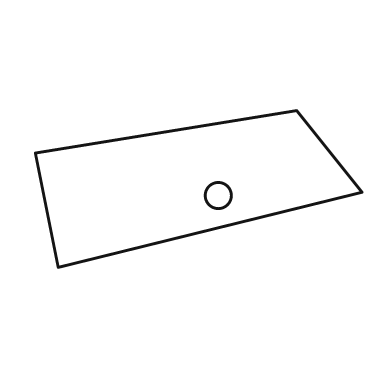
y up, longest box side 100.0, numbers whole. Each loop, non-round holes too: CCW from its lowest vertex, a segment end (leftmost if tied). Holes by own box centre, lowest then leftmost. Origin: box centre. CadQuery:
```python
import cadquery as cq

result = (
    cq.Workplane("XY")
    .moveTo(-43.0, -24.0)
    .lineTo(50.0, -1.0)
    .lineTo(30.0, 24.0)
    .lineTo(-50.0, 11.0)
    .close()
    .moveTo(6.0, -2.0)
    .circle(4.0)
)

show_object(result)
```